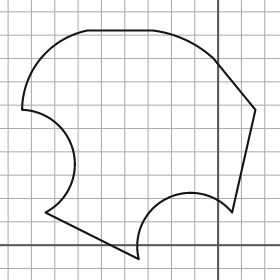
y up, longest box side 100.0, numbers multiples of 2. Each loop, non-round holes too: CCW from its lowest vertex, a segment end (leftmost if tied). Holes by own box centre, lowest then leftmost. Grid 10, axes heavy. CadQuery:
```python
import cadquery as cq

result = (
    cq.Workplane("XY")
    .moveTo(-34.0, -6.0)
    .threePointArc((-22.0, 20.0), (6.0, 14.0))
    .lineTo(16.0, 58.0)
    .lineTo(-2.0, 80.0)
    .threePointArc((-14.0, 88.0), (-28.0, 92.0))
    .lineTo(-56.0, 92.0)
    .threePointArc((-76.0, 80.0), (-84.0, 58.0))
    .threePointArc((-62.0, 40.0), (-74.0, 14.0))
    .close()
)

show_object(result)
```